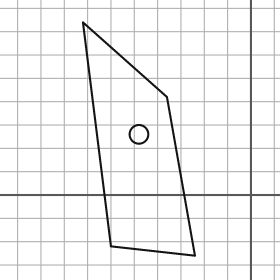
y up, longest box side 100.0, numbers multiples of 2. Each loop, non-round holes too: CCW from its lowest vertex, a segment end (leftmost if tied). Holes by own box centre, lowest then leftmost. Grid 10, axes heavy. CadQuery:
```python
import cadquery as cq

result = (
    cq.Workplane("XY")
    .moveTo(-24.0, -26.0)
    .lineTo(-36.0, 42.0)
    .lineTo(-72.0, 74.0)
    .lineTo(-60.0, -22.0)
    .close()
    .moveTo(-48.0, 26.0)
    .circle(4.0)
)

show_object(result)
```